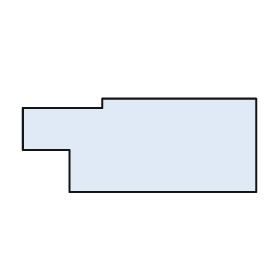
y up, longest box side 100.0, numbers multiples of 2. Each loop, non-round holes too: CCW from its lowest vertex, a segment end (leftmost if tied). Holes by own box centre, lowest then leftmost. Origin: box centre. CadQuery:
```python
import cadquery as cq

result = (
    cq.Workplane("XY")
    .moveTo(-30.0, -20.0)
    .lineTo(50.0, -20.0)
    .lineTo(50.0, 20.0)
    .lineTo(-16.0, 20.0)
    .lineTo(-16.0, 16.0)
    .lineTo(-50.0, 16.0)
    .lineTo(-50.0, -2.0)
    .lineTo(-30.0, -2.0)
    .close()
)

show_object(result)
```